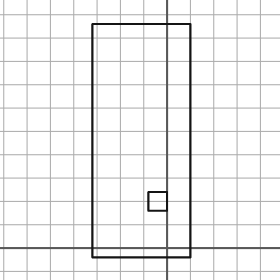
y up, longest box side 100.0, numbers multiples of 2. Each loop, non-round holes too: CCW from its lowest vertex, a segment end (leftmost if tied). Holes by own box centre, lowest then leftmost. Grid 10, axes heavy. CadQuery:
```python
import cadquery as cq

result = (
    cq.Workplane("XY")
    .moveTo(-32.0, -4.0)
    .lineTo(10.0, -4.0)
    .lineTo(10.0, 96.0)
    .lineTo(-32.0, 96.0)
    .close()
    .moveTo(-8.0, 16.0)
    .lineTo(0.0, 16.0)
    .lineTo(0.0, 24.0)
    .lineTo(-8.0, 24.0)
    .close()
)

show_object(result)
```